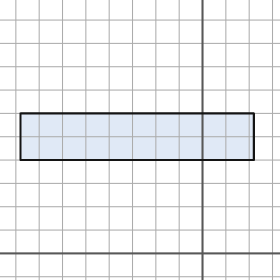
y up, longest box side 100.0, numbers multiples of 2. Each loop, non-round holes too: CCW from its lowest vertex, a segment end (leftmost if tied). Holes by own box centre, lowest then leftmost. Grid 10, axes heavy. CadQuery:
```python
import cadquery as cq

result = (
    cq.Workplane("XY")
    .moveTo(-78.0, 40.0)
    .lineTo(22.0, 40.0)
    .lineTo(22.0, 60.0)
    .lineTo(-78.0, 60.0)
    .close()
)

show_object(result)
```